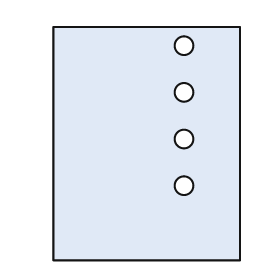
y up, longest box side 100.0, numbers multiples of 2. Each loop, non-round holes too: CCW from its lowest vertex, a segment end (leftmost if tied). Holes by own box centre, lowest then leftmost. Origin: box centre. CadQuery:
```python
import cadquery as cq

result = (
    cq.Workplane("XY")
    .moveTo(-40.0, -50.0)
    .lineTo(40.0, -50.0)
    .lineTo(40.0, 50.0)
    .lineTo(-40.0, 50.0)
    .close()
    .moveTo(16.0, -18.0)
    .circle(4.0)
    .moveTo(16.0, 2.0)
    .circle(4.0)
    .moveTo(16.0, 22.0)
    .circle(4.0)
    .moveTo(16.0, 42.0)
    .circle(4.0)
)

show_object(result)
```